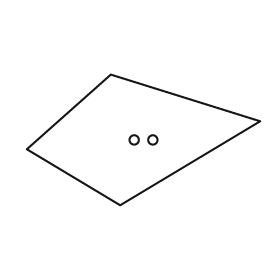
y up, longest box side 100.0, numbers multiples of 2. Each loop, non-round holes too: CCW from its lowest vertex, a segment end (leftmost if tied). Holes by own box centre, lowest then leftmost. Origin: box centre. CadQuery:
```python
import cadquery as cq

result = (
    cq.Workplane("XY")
    .moveTo(-10.0, -28.0)
    .lineTo(50.0, 8.0)
    .lineTo(-14.0, 28.0)
    .lineTo(-50.0, -4.0)
    .close()
    .moveTo(-4.0, 0.0)
    .circle(2.0)
    .moveTo(4.0, 0.0)
    .circle(2.0)
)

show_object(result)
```